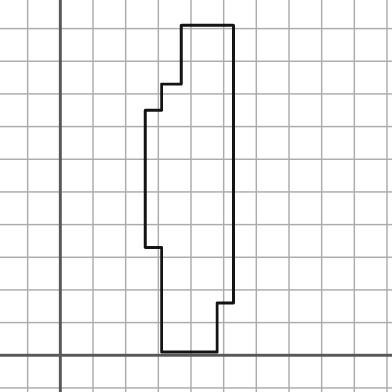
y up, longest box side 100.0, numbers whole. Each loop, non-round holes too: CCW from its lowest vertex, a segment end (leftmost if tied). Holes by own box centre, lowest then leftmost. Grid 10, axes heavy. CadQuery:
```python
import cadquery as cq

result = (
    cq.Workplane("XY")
    .moveTo(31.0, 1.0)
    .lineTo(48.0, 1.0)
    .lineTo(48.0, 16.0)
    .lineTo(53.0, 16.0)
    .lineTo(53.0, 101.0)
    .lineTo(37.0, 101.0)
    .lineTo(37.0, 83.0)
    .lineTo(31.0, 83.0)
    .lineTo(31.0, 75.0)
    .lineTo(26.0, 75.0)
    .lineTo(26.0, 33.0)
    .lineTo(31.0, 33.0)
    .close()
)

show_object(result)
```